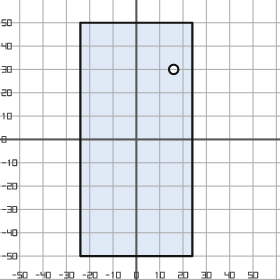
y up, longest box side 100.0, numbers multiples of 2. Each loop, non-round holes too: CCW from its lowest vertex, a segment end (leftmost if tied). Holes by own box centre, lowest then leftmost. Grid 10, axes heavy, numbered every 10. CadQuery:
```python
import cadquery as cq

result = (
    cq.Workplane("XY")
    .moveTo(-24.0, -50.0)
    .lineTo(24.0, -50.0)
    .lineTo(24.0, 50.0)
    .lineTo(-24.0, 50.0)
    .close()
    .moveTo(16.0, 30.0)
    .circle(2.0)
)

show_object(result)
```